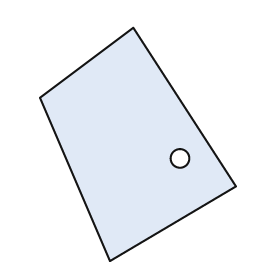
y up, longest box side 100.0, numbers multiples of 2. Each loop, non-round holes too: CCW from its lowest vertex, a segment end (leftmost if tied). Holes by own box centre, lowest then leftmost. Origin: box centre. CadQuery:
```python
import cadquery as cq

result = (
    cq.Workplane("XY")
    .moveTo(-12.0, -50.0)
    .lineTo(42.0, -18.0)
    .lineTo(-2.0, 50.0)
    .lineTo(-42.0, 20.0)
    .close()
    .moveTo(18.0, -6.0)
    .circle(4.0)
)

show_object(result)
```